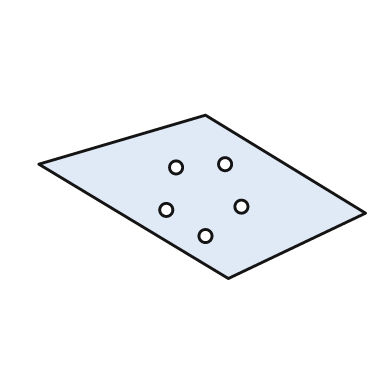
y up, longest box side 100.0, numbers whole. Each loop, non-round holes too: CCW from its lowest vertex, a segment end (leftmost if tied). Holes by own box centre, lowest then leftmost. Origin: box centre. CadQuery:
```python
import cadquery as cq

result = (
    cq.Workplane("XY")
    .moveTo(8.0, -25.0)
    .lineTo(50.0, -5.0)
    .lineTo(1.0, 25.0)
    .lineTo(-50.0, 10.0)
    .close()
    .moveTo(1.0, -12.0)
    .circle(2.0)
    .moveTo(-11.0, -4.0)
    .circle(2.0)
    .moveTo(12.0, -3.0)
    .circle(2.0)
    .moveTo(-8.0, 9.0)
    .circle(2.0)
    .moveTo(7.0, 10.0)
    .circle(2.0)
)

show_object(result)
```